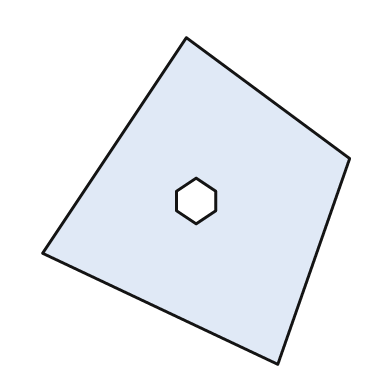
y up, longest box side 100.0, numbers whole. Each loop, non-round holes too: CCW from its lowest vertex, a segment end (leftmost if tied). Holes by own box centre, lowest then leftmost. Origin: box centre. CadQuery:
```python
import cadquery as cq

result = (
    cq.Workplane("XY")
    .moveTo(25.0, -50.0)
    .lineTo(47.0, 13.0)
    .lineTo(-3.0, 50.0)
    .lineTo(-47.0, -16.0)
    .close()
    .moveTo(0.0, -7.0)
    .lineTo(6.0, -3.0)
    .lineTo(6.0, 3.0)
    .lineTo(0.0, 7.0)
    .lineTo(-6.0, 3.0)
    .lineTo(-6.0, -3.0)
    .close()
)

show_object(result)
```